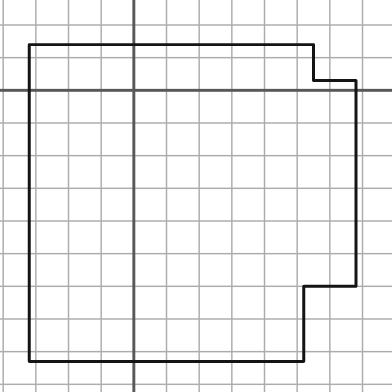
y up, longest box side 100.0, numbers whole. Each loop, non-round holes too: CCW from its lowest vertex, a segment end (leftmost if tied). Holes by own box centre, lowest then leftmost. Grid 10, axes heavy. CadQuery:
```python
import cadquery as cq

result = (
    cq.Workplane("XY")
    .moveTo(-32.0, -83.0)
    .lineTo(52.0, -83.0)
    .lineTo(52.0, -60.0)
    .lineTo(68.0, -60.0)
    .lineTo(68.0, 3.0)
    .lineTo(55.0, 3.0)
    .lineTo(55.0, 14.0)
    .lineTo(-32.0, 14.0)
    .close()
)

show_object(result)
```